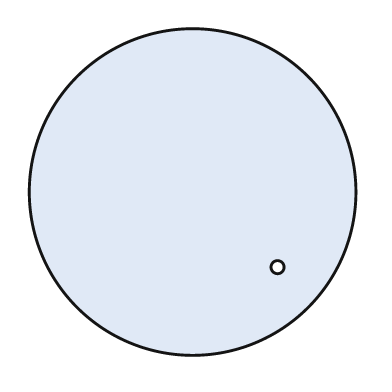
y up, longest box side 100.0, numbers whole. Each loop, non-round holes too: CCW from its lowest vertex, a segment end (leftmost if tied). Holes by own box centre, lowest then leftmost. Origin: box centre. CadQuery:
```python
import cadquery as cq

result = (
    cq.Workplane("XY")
    .moveTo(0.0, 0.0)
    .circle(50.0)
    .moveTo(26.0, -23.0)
    .circle(2.0)
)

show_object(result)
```